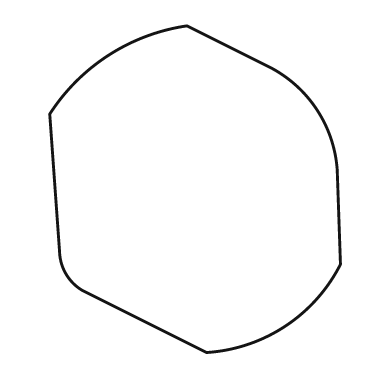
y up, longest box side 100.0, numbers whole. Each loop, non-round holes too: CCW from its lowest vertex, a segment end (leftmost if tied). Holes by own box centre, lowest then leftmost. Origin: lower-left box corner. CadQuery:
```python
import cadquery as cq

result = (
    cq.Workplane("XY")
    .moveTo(48.0, 0.0)
    .threePointArc((72.0, 8.0), (89.0, 27.0))
    .lineTo(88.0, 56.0)
    .threePointArc((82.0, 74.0), (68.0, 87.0))
    .lineTo(42.0, 100.0)
    .threePointArc((18.0, 91.0), (0.0, 73.0))
    .lineTo(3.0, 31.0)
    .threePointArc((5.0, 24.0), (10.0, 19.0))
    .close()
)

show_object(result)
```